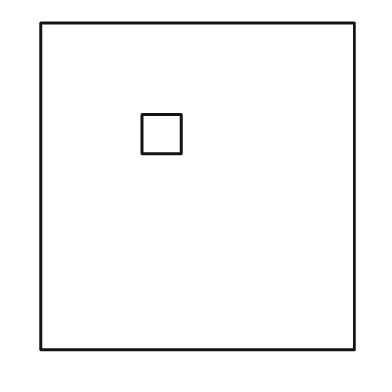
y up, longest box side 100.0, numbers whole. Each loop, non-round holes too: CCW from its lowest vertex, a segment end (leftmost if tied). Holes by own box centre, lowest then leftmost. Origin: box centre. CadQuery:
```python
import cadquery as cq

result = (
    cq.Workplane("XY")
    .moveTo(-48.0, -50.0)
    .lineTo(48.0, -50.0)
    .lineTo(48.0, 50.0)
    .lineTo(-48.0, 50.0)
    .close()
    .moveTo(-17.0, 10.0)
    .lineTo(-5.0, 10.0)
    .lineTo(-5.0, 22.0)
    .lineTo(-17.0, 22.0)
    .close()
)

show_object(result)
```